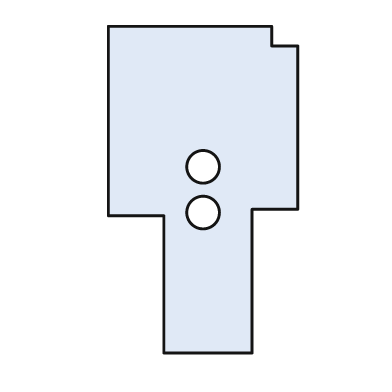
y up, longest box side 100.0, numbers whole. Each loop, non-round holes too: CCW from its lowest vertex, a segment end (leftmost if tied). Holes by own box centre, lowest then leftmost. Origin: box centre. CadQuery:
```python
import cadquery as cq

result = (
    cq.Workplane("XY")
    .moveTo(-12.0, -50.0)
    .lineTo(15.0, -50.0)
    .lineTo(15.0, -6.0)
    .lineTo(29.0, -6.0)
    .lineTo(29.0, 44.0)
    .lineTo(21.0, 44.0)
    .lineTo(21.0, 50.0)
    .lineTo(-29.0, 50.0)
    .lineTo(-29.0, -8.0)
    .lineTo(-12.0, -8.0)
    .close()
    .moveTo(0.0, -7.0)
    .circle(5.0)
    .moveTo(0.0, 7.0)
    .circle(5.0)
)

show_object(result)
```